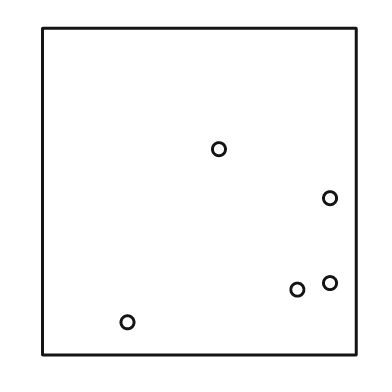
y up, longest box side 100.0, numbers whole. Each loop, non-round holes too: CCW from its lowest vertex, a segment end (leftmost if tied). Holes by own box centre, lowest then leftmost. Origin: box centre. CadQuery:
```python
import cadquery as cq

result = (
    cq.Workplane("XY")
    .moveTo(-48.0, -50.0)
    .lineTo(48.0, -50.0)
    .lineTo(48.0, 50.0)
    .lineTo(-48.0, 50.0)
    .close()
    .moveTo(-22.0, -40.0)
    .circle(2.0)
    .moveTo(30.0, -30.0)
    .circle(2.0)
    .moveTo(40.0, -28.0)
    .circle(2.0)
    .moveTo(40.0, -2.0)
    .circle(2.0)
    .moveTo(6.0, 13.0)
    .circle(2.0)
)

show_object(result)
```